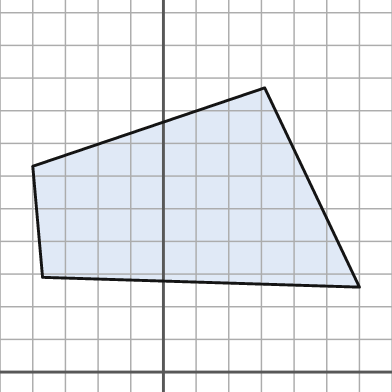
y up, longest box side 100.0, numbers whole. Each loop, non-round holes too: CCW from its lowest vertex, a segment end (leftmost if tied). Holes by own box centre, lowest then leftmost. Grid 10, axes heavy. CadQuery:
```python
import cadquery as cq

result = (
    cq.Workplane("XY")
    .moveTo(60.0, 26.0)
    .lineTo(31.0, 87.0)
    .lineTo(-40.0, 63.0)
    .lineTo(-37.0, 29.0)
    .close()
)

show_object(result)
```